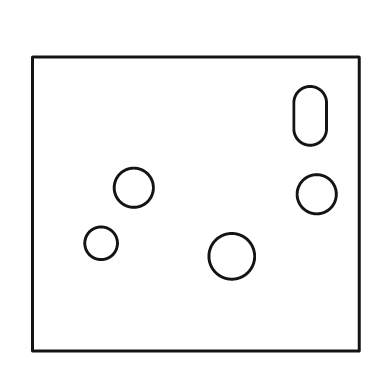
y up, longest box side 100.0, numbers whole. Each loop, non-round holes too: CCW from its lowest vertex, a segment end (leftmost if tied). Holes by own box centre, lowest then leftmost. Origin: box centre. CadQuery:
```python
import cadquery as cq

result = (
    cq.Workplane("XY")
    .moveTo(-50.0, -45.0)
    .lineTo(50.0, -45.0)
    .lineTo(50.0, 45.0)
    .lineTo(-50.0, 45.0)
    .close()
    .moveTo(11.0, -16.0)
    .circle(7.0)
    .moveTo(-29.0, -12.0)
    .circle(5.0)
    .moveTo(37.0, 3.0)
    .circle(6.0)
    .moveTo(-19.0, 5.0)
    .circle(6.0)
    .moveTo(30.0, 23.0)
    .threePointArc((35.0, 18.0), (40.0, 23.0))
    .lineTo(40.0, 31.0)
    .threePointArc((35.0, 36.0), (30.0, 31.0))
    .close()
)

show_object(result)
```